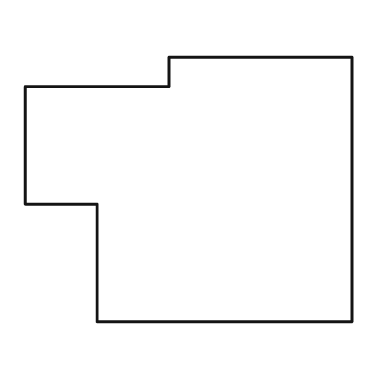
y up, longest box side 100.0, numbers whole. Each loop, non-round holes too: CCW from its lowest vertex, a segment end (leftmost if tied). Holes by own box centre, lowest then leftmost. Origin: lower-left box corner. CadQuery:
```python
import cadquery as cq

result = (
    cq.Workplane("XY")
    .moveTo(22.0, 0.0)
    .lineTo(100.0, 0.0)
    .lineTo(100.0, 81.0)
    .lineTo(44.0, 81.0)
    .lineTo(44.0, 72.0)
    .lineTo(0.0, 72.0)
    .lineTo(0.0, 36.0)
    .lineTo(22.0, 36.0)
    .close()
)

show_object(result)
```